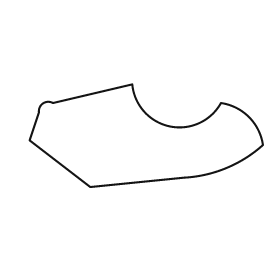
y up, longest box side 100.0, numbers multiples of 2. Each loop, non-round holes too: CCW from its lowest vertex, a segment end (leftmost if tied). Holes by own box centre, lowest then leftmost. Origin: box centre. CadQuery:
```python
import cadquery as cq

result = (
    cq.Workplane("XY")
    .moveTo(-24.0, -22.0)
    .lineTo(16.0, -18.0)
    .threePointArc((34.0, -14.0), (50.0, -4.0))
    .threePointArc((44.0, 8.0), (32.0, 14.0))
    .threePointArc((10.0, 4.0), (-6.0, 22.0))
    .lineTo(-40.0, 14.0)
    .threePointArc((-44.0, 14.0), (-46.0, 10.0))
    .lineTo(-50.0, -2.0)
    .close()
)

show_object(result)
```